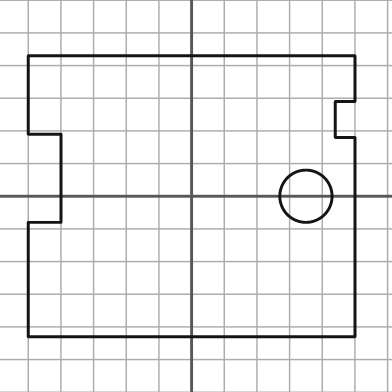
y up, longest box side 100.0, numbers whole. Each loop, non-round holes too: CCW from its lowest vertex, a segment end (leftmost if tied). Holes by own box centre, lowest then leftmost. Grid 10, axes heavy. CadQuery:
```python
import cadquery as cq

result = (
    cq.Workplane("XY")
    .moveTo(-50.0, -43.0)
    .lineTo(50.0, -43.0)
    .lineTo(50.0, 18.0)
    .lineTo(44.0, 18.0)
    .lineTo(44.0, 29.0)
    .lineTo(50.0, 29.0)
    .lineTo(50.0, 43.0)
    .lineTo(-50.0, 43.0)
    .lineTo(-50.0, 19.0)
    .lineTo(-40.0, 19.0)
    .lineTo(-40.0, -8.0)
    .lineTo(-50.0, -8.0)
    .close()
    .moveTo(35.0, 0.0)
    .circle(8.0)
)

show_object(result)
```